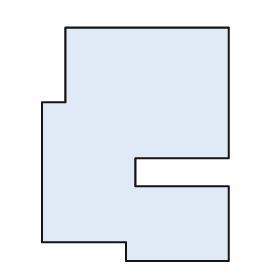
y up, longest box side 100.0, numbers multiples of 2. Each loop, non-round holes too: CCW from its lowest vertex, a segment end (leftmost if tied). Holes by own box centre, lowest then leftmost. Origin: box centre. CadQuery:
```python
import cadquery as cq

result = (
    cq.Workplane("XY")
    .moveTo(-4.0, -50.0)
    .lineTo(40.0, -50.0)
    .lineTo(40.0, -18.0)
    .lineTo(0.0, -18.0)
    .lineTo(0.0, -6.0)
    .lineTo(40.0, -6.0)
    .lineTo(40.0, 50.0)
    .lineTo(-30.0, 50.0)
    .lineTo(-30.0, 18.0)
    .lineTo(-40.0, 18.0)
    .lineTo(-40.0, -42.0)
    .lineTo(-4.0, -42.0)
    .close()
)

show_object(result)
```